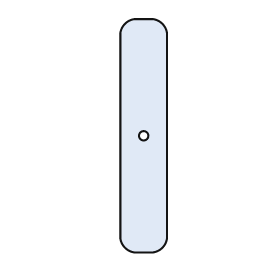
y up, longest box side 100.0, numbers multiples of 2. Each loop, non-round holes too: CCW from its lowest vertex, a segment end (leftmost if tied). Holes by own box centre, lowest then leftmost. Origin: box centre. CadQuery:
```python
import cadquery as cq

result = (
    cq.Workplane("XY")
    .moveTo(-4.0, -50.0)
    .lineTo(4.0, -50.0)
    .threePointArc((8.0, -48.0), (10.0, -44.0))
    .lineTo(10.0, 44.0)
    .threePointArc((8.0, 48.0), (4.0, 50.0))
    .lineTo(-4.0, 50.0)
    .threePointArc((-8.0, 48.0), (-10.0, 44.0))
    .lineTo(-10.0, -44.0)
    .threePointArc((-8.0, -48.0), (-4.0, -50.0))
    .close()
    .moveTo(0.0, 0.0)
    .circle(2.0)
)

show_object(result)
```